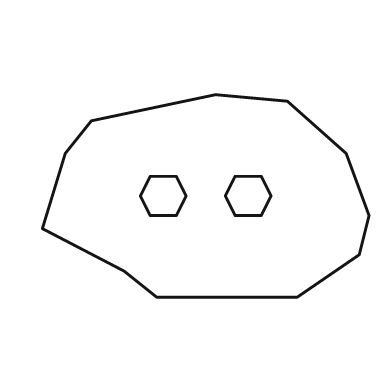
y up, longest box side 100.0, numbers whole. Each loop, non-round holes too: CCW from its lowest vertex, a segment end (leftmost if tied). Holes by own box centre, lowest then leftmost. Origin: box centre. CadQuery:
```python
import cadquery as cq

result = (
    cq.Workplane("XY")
    .moveTo(-15.0, -31.0)
    .lineTo(28.0, -31.0)
    .lineTo(47.0, -18.0)
    .lineTo(50.0, -6.0)
    .lineTo(43.0, 13.0)
    .lineTo(25.0, 29.0)
    .lineTo(3.0, 31.0)
    .lineTo(-35.0, 23.0)
    .lineTo(-43.0, 13.0)
    .lineTo(-50.0, -10.0)
    .lineTo(-25.0, -23.0)
    .close()
    .moveTo(-17.0, -6.0)
    .lineTo(-9.0, -6.0)
    .lineTo(-6.0, 0.0)
    .lineTo(-9.0, 6.0)
    .lineTo(-17.0, 6.0)
    .lineTo(-20.0, 0.0)
    .close()
    .moveTo(9.0, -6.0)
    .lineTo(17.0, -6.0)
    .lineTo(20.0, 0.0)
    .lineTo(17.0, 6.0)
    .lineTo(9.0, 6.0)
    .lineTo(6.0, 0.0)
    .close()
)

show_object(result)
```